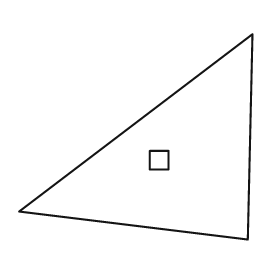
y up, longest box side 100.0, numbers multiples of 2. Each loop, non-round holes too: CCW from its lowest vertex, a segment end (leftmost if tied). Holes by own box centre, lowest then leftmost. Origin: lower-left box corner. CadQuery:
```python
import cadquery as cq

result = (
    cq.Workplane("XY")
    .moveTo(98.0, 0.0)
    .lineTo(100.0, 88.0)
    .lineTo(0.0, 12.0)
    .close()
    .moveTo(56.0, 30.0)
    .lineTo(64.0, 30.0)
    .lineTo(64.0, 38.0)
    .lineTo(56.0, 38.0)
    .close()
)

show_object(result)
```